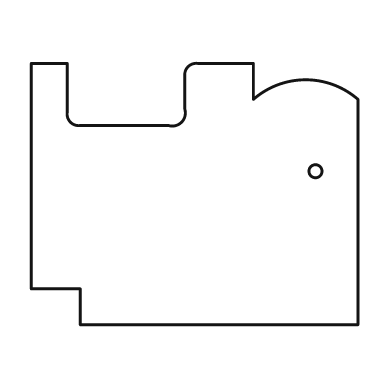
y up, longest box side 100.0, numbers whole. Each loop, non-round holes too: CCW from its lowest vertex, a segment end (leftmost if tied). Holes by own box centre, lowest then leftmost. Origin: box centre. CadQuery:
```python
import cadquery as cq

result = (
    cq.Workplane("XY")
    .moveTo(-35.0, -40.0)
    .lineTo(50.0, -40.0)
    .lineTo(50.0, 29.0)
    .threePointArc((34.0, 35.0), (18.0, 29.0))
    .lineTo(18.0, 40.0)
    .lineTo(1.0, 40.0)
    .threePointArc((-2.0, 39.0), (-3.0, 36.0))
    .lineTo(-3.0, 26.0)
    .threePointArc((-4.0, 22.0), (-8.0, 21.0))
    .lineTo(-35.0, 21.0)
    .threePointArc((-38.0, 22.0), (-39.0, 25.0))
    .lineTo(-39.0, 40.0)
    .lineTo(-50.0, 40.0)
    .lineTo(-50.0, -29.0)
    .lineTo(-35.0, -29.0)
    .close()
    .moveTo(37.0, 7.0)
    .circle(2.0)
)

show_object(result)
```